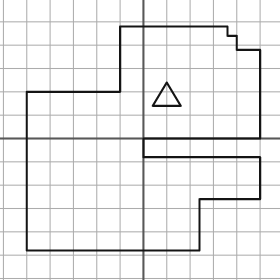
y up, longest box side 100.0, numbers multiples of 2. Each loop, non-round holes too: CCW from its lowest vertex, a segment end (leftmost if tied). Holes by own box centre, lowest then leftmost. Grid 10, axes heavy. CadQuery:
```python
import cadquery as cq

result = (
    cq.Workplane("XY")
    .moveTo(-50.0, -48.0)
    .lineTo(24.0, -48.0)
    .lineTo(24.0, -26.0)
    .lineTo(50.0, -26.0)
    .lineTo(50.0, -8.0)
    .lineTo(0.0, -8.0)
    .lineTo(0.0, 0.0)
    .lineTo(50.0, 0.0)
    .lineTo(50.0, 38.0)
    .lineTo(40.0, 38.0)
    .lineTo(40.0, 44.0)
    .lineTo(36.0, 44.0)
    .lineTo(36.0, 48.0)
    .lineTo(-10.0, 48.0)
    .lineTo(-10.0, 20.0)
    .lineTo(-50.0, 20.0)
    .close()
    .moveTo(4.0, 14.0)
    .lineTo(16.0, 14.0)
    .lineTo(10.0, 24.0)
    .close()
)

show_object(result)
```